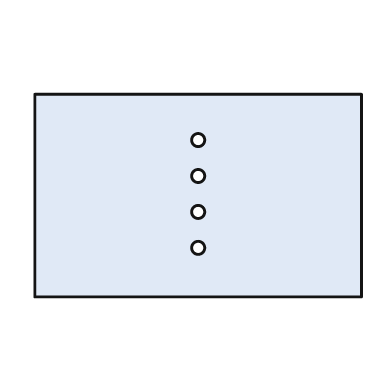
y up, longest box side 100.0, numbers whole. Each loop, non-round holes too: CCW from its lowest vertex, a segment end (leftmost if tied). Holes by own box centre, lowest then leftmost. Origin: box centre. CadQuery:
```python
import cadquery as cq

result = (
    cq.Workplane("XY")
    .moveTo(-50.0, -31.0)
    .lineTo(50.0, -31.0)
    .lineTo(50.0, 31.0)
    .lineTo(-50.0, 31.0)
    .close()
    .moveTo(0.0, -16.0)
    .circle(2.0)
    .moveTo(0.0, -5.0)
    .circle(2.0)
    .moveTo(0.0, 6.0)
    .circle(2.0)
    .moveTo(0.0, 17.0)
    .circle(2.0)
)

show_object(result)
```